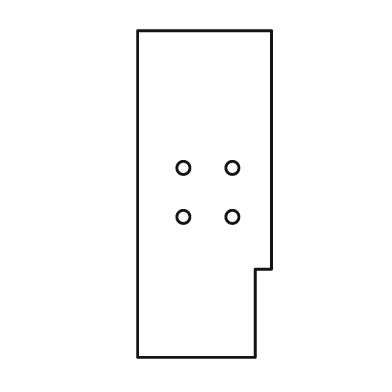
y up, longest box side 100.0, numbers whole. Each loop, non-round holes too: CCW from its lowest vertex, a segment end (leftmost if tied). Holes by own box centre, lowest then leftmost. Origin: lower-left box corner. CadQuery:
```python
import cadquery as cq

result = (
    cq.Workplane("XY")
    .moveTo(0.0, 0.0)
    .lineTo(36.0, 0.0)
    .lineTo(36.0, 27.0)
    .lineTo(41.0, 27.0)
    .lineTo(41.0, 100.0)
    .lineTo(0.0, 100.0)
    .close()
    .moveTo(14.0, 43.0)
    .circle(2.0)
    .moveTo(29.0, 43.0)
    .circle(2.0)
    .moveTo(14.0, 58.0)
    .circle(2.0)
    .moveTo(29.0, 58.0)
    .circle(2.0)
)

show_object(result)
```